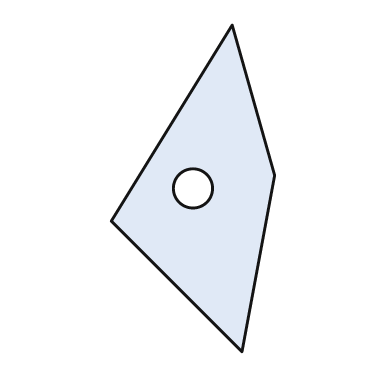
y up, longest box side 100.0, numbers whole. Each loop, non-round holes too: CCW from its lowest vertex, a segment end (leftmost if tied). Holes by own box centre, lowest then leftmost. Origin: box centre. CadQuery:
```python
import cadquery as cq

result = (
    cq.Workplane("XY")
    .moveTo(15.0, -50.0)
    .lineTo(25.0, 4.0)
    .lineTo(12.0, 50.0)
    .lineTo(-25.0, -10.0)
    .close()
    .moveTo(0.0, 0.0)
    .circle(6.0)
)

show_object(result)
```